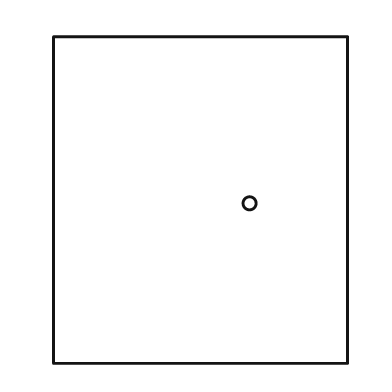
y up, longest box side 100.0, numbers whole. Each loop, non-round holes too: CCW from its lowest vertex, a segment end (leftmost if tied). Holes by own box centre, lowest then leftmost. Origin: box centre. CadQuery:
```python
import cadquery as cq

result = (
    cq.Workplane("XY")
    .moveTo(-45.0, -50.0)
    .lineTo(45.0, -50.0)
    .lineTo(45.0, 50.0)
    .lineTo(-45.0, 50.0)
    .close()
    .moveTo(15.0, -1.0)
    .circle(2.0)
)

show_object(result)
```